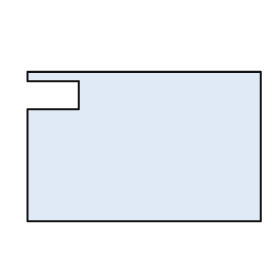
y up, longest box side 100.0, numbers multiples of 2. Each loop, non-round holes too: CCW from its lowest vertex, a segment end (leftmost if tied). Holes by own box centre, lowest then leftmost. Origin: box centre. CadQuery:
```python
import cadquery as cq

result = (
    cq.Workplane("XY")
    .moveTo(-50.0, -32.0)
    .lineTo(50.0, -32.0)
    .lineTo(50.0, 32.0)
    .lineTo(-50.0, 32.0)
    .lineTo(-50.0, 28.0)
    .lineTo(-28.0, 28.0)
    .lineTo(-28.0, 16.0)
    .lineTo(-50.0, 16.0)
    .close()
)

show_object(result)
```